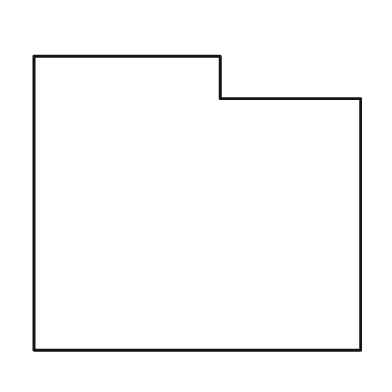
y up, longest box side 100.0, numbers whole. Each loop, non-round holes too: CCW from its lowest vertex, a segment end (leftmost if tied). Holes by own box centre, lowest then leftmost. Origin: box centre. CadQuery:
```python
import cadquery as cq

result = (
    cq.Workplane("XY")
    .moveTo(-50.0, -45.0)
    .lineTo(50.0, -45.0)
    .lineTo(50.0, 32.0)
    .lineTo(7.0, 32.0)
    .lineTo(7.0, 45.0)
    .lineTo(-50.0, 45.0)
    .close()
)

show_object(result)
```